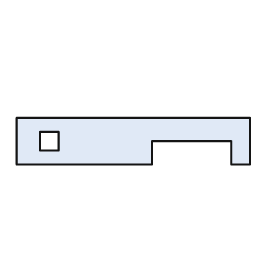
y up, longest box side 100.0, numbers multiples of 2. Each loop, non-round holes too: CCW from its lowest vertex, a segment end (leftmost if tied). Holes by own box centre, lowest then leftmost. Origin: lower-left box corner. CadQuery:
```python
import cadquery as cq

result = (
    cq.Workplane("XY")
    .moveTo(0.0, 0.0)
    .lineTo(58.0, 0.0)
    .lineTo(58.0, 10.0)
    .lineTo(92.0, 10.0)
    .lineTo(92.0, 0.0)
    .lineTo(100.0, 0.0)
    .lineTo(100.0, 20.0)
    .lineTo(0.0, 20.0)
    .close()
    .moveTo(10.0, 6.0)
    .lineTo(18.0, 6.0)
    .lineTo(18.0, 14.0)
    .lineTo(10.0, 14.0)
    .close()
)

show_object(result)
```